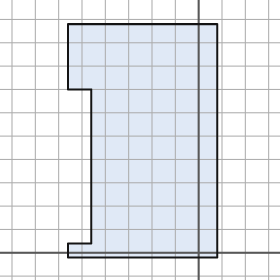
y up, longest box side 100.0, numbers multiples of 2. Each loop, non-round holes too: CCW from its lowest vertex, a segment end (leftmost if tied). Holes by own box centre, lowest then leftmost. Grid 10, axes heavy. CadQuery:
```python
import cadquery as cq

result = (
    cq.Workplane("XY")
    .moveTo(-56.0, -2.0)
    .lineTo(8.0, -2.0)
    .lineTo(8.0, 98.0)
    .lineTo(-56.0, 98.0)
    .lineTo(-56.0, 70.0)
    .lineTo(-46.0, 70.0)
    .lineTo(-46.0, 4.0)
    .lineTo(-56.0, 4.0)
    .close()
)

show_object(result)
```